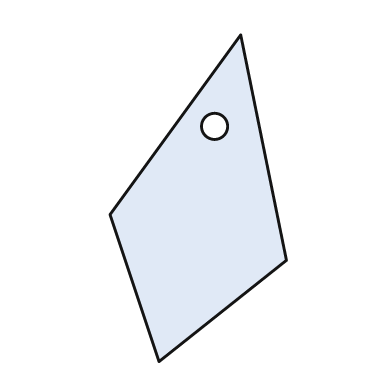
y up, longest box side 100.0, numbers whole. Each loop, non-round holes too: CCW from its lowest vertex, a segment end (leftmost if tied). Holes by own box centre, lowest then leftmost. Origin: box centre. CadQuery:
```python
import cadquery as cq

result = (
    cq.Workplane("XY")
    .moveTo(-12.0, -50.0)
    .lineTo(27.0, -19.0)
    .lineTo(13.0, 50.0)
    .lineTo(-27.0, -5.0)
    .close()
    .moveTo(5.0, 22.0)
    .circle(4.0)
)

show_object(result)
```